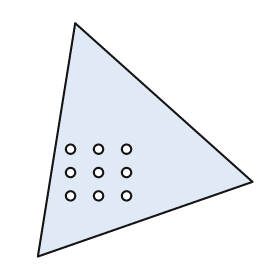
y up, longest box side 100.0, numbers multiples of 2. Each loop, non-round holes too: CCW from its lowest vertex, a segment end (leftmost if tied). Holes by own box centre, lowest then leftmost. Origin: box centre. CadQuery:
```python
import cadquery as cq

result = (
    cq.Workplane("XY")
    .moveTo(-46.0, -50.0)
    .lineTo(46.0, -18.0)
    .lineTo(-30.0, 50.0)
    .close()
    .moveTo(-32.0, -24.0)
    .circle(2.0)
    .moveTo(-20.0, -24.0)
    .circle(2.0)
    .moveTo(-8.0, -24.0)
    .circle(2.0)
    .moveTo(-32.0, -14.0)
    .circle(2.0)
    .moveTo(-20.0, -14.0)
    .circle(2.0)
    .moveTo(-8.0, -14.0)
    .circle(2.0)
    .moveTo(-32.0, -4.0)
    .circle(2.0)
    .moveTo(-20.0, -4.0)
    .circle(2.0)
    .moveTo(-8.0, -4.0)
    .circle(2.0)
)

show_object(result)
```